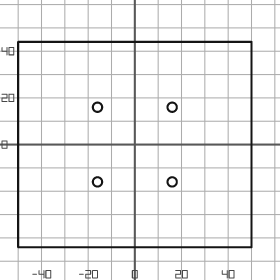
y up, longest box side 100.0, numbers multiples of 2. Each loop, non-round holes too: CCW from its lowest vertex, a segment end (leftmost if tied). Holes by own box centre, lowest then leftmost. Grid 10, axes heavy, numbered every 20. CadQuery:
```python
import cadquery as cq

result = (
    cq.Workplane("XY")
    .moveTo(-50.0, -44.0)
    .lineTo(50.0, -44.0)
    .lineTo(50.0, 44.0)
    .lineTo(-50.0, 44.0)
    .close()
    .moveTo(-16.0, -16.0)
    .circle(2.0)
    .moveTo(16.0, -16.0)
    .circle(2.0)
    .moveTo(-16.0, 16.0)
    .circle(2.0)
    .moveTo(16.0, 16.0)
    .circle(2.0)
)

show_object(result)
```